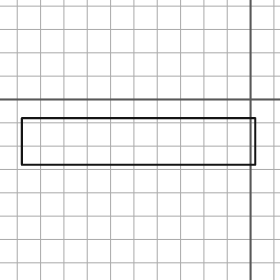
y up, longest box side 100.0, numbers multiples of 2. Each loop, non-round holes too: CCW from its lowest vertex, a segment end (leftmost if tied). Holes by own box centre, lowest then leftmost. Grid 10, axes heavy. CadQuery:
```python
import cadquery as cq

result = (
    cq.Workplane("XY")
    .moveTo(-98.0, -28.0)
    .lineTo(2.0, -28.0)
    .lineTo(2.0, -8.0)
    .lineTo(-98.0, -8.0)
    .close()
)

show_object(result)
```